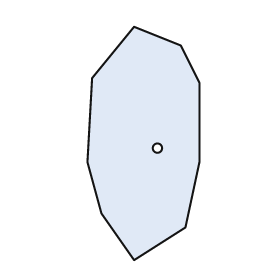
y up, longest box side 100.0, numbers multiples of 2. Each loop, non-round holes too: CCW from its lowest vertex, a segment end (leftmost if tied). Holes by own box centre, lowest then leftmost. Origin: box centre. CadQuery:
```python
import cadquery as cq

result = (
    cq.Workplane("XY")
    .moveTo(-4.0, -50.0)
    .lineTo(18.0, -36.0)
    .lineTo(24.0, -8.0)
    .lineTo(24.0, 26.0)
    .lineTo(16.0, 42.0)
    .lineTo(-4.0, 50.0)
    .lineTo(-22.0, 28.0)
    .lineTo(-24.0, -8.0)
    .lineTo(-18.0, -30.0)
    .close()
    .moveTo(6.0, -2.0)
    .circle(2.0)
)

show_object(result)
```